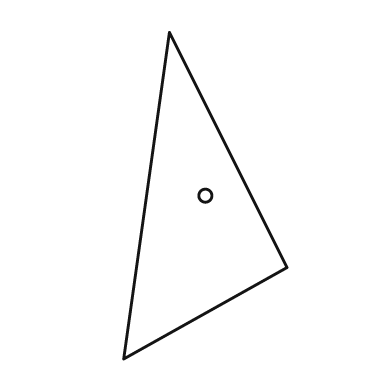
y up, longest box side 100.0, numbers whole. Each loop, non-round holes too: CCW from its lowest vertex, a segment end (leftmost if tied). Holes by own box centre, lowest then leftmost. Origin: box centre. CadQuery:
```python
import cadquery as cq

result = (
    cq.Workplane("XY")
    .moveTo(-25.0, -50.0)
    .lineTo(25.0, -22.0)
    .lineTo(-11.0, 50.0)
    .close()
    .moveTo(0.0, 0.0)
    .circle(2.0)
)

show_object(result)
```